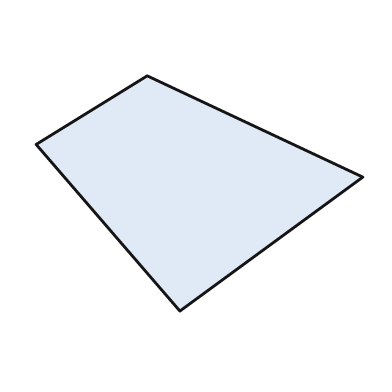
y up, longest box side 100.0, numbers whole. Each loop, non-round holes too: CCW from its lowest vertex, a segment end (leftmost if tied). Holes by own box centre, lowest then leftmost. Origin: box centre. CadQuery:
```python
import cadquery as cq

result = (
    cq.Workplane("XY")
    .moveTo(-6.0, -36.0)
    .lineTo(50.0, 5.0)
    .lineTo(-16.0, 36.0)
    .lineTo(-50.0, 15.0)
    .close()
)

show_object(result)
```